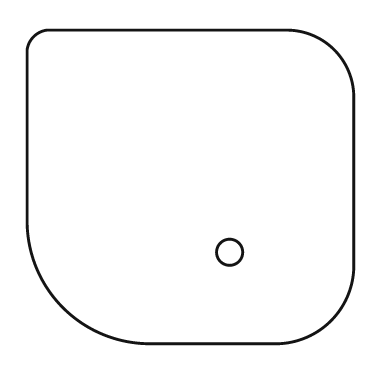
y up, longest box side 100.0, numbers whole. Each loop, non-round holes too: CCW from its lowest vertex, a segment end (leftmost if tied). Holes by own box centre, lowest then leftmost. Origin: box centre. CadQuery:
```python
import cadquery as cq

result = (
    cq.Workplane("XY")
    .moveTo(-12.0, -48.0)
    .lineTo(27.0, -48.0)
    .threePointArc((43.0, -41.0), (50.0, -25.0))
    .lineTo(50.0, 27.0)
    .threePointArc((44.0, 42.0), (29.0, 48.0))
    .lineTo(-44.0, 48.0)
    .threePointArc((-48.0, 46.0), (-50.0, 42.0))
    .lineTo(-50.0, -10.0)
    .threePointArc((-39.0, -37.0), (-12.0, -48.0))
    .close()
    .moveTo(12.0, -20.0)
    .circle(4.0)
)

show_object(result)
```